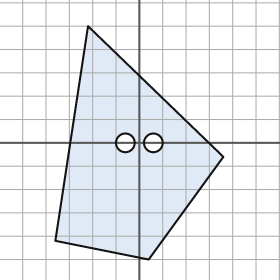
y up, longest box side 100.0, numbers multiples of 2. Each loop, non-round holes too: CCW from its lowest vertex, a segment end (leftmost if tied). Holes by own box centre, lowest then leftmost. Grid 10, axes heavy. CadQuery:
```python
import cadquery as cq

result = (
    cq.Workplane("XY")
    .moveTo(4.0, -50.0)
    .lineTo(36.0, -6.0)
    .lineTo(-22.0, 50.0)
    .lineTo(-36.0, -42.0)
    .close()
    .moveTo(-6.0, 0.0)
    .circle(4.0)
    .moveTo(6.0, 0.0)
    .circle(4.0)
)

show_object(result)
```